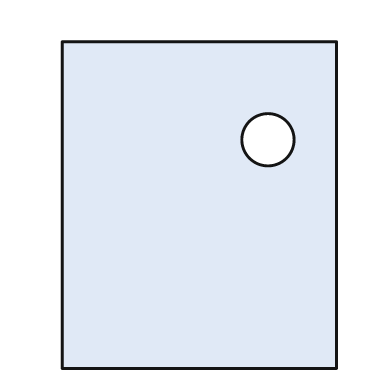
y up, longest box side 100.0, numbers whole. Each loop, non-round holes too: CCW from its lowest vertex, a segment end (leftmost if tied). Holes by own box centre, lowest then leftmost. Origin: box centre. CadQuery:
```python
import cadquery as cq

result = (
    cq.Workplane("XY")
    .moveTo(-42.0, -50.0)
    .lineTo(42.0, -50.0)
    .lineTo(42.0, 50.0)
    .lineTo(-42.0, 50.0)
    .close()
    .moveTo(21.0, 20.0)
    .circle(8.0)
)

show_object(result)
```